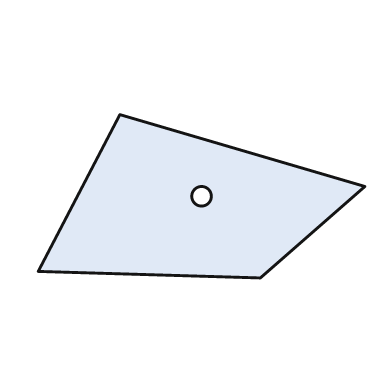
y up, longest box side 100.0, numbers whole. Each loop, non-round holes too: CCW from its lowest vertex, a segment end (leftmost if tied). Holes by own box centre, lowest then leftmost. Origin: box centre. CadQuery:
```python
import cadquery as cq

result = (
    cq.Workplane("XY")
    .moveTo(18.0, -25.0)
    .lineTo(50.0, 3.0)
    .lineTo(-25.0, 25.0)
    .lineTo(-50.0, -23.0)
    .close()
    .moveTo(0.0, 0.0)
    .circle(3.0)
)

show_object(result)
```